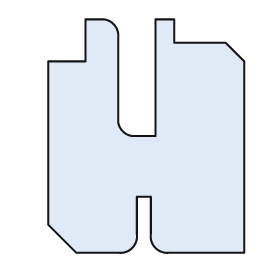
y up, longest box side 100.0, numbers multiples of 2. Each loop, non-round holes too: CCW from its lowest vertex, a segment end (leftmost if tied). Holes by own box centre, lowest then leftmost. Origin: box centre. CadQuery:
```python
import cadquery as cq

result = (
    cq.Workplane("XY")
    .moveTo(-30.0, -50.0)
    .lineTo(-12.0, -50.0)
    .threePointArc((-6.0, -48.0), (-4.0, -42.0))
    .lineTo(-4.0, -26.0)
    .lineTo(2.0, -26.0)
    .lineTo(2.0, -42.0)
    .threePointArc((4.0, -48.0), (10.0, -50.0))
    .lineTo(42.0, -50.0)
    .lineTo(42.0, 32.0)
    .lineTo(34.0, 40.0)
    .lineTo(12.0, 40.0)
    .lineTo(12.0, 50.0)
    .lineTo(4.0, 50.0)
    .lineTo(4.0, 0.0)
    .lineTo(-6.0, 0.0)
    .threePointArc((-10.0, 2.0), (-12.0, 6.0))
    .lineTo(-12.0, 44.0)
    .threePointArc((-14.0, 48.0), (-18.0, 50.0))
    .lineTo(-26.0, 50.0)
    .lineTo(-26.0, 32.0)
    .lineTo(-42.0, 32.0)
    .lineTo(-42.0, -38.0)
    .close()
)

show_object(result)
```